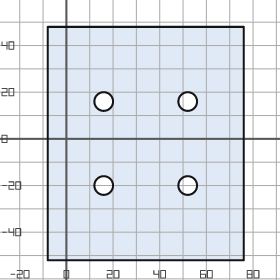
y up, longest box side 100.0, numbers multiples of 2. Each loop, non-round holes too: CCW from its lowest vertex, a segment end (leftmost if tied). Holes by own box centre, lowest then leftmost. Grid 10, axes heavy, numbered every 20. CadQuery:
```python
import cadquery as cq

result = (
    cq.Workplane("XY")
    .moveTo(-8.0, -52.0)
    .lineTo(76.0, -52.0)
    .lineTo(76.0, 48.0)
    .lineTo(-8.0, 48.0)
    .close()
    .moveTo(16.0, -20.0)
    .circle(4.0)
    .moveTo(52.0, -20.0)
    .circle(4.0)
    .moveTo(16.0, 16.0)
    .circle(4.0)
    .moveTo(52.0, 16.0)
    .circle(4.0)
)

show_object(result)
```